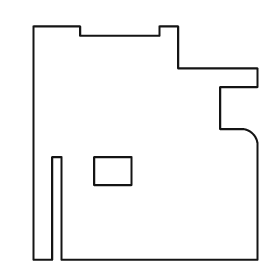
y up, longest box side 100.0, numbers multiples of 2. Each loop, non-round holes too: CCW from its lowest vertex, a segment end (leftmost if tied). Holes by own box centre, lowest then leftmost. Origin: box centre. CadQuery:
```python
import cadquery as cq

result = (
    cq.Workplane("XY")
    .moveTo(-48.0, -50.0)
    .lineTo(-40.0, -50.0)
    .lineTo(-40.0, -6.0)
    .lineTo(-36.0, -6.0)
    .lineTo(-36.0, -50.0)
    .lineTo(48.0, -50.0)
    .lineTo(48.0, 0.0)
    .threePointArc((46.0, 4.0), (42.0, 6.0))
    .lineTo(32.0, 6.0)
    .lineTo(32.0, 24.0)
    .lineTo(48.0, 24.0)
    .lineTo(48.0, 32.0)
    .lineTo(14.0, 32.0)
    .lineTo(14.0, 50.0)
    .lineTo(6.0, 50.0)
    .lineTo(6.0, 46.0)
    .lineTo(-28.0, 46.0)
    .lineTo(-28.0, 50.0)
    .lineTo(-48.0, 50.0)
    .close()
    .moveTo(-22.0, -18.0)
    .lineTo(-6.0, -18.0)
    .lineTo(-6.0, -6.0)
    .lineTo(-22.0, -6.0)
    .close()
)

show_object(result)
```